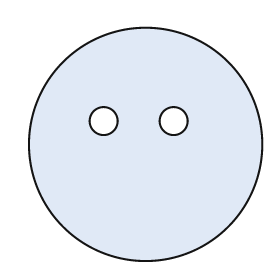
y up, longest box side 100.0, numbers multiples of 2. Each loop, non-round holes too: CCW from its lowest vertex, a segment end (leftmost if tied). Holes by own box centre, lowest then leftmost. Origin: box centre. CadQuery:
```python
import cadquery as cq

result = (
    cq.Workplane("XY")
    .moveTo(0.0, 0.0)
    .circle(50.0)
    .moveTo(-18.0, 10.0)
    .circle(6.0)
    .moveTo(12.0, 10.0)
    .circle(6.0)
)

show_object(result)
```